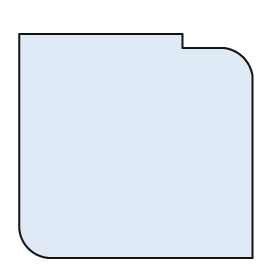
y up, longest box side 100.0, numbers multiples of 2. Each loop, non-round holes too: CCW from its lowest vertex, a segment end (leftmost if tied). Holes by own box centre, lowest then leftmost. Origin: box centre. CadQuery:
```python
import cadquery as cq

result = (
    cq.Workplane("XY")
    .moveTo(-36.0, -48.0)
    .lineTo(50.0, -48.0)
    .lineTo(50.0, 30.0)
    .threePointArc((46.0, 38.0), (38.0, 42.0))
    .lineTo(20.0, 42.0)
    .lineTo(20.0, 48.0)
    .lineTo(-50.0, 48.0)
    .lineTo(-50.0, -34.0)
    .threePointArc((-46.0, -44.0), (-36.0, -48.0))
    .close()
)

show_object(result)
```